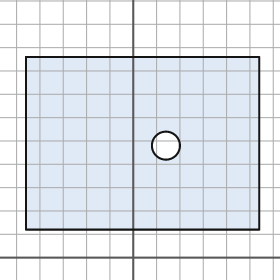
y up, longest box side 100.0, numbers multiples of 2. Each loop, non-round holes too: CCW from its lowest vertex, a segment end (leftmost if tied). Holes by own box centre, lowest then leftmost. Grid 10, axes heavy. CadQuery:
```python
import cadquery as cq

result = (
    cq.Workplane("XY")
    .moveTo(-46.0, 12.0)
    .lineTo(54.0, 12.0)
    .lineTo(54.0, 86.0)
    .lineTo(-46.0, 86.0)
    .close()
    .moveTo(14.0, 48.0)
    .circle(6.0)
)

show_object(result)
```